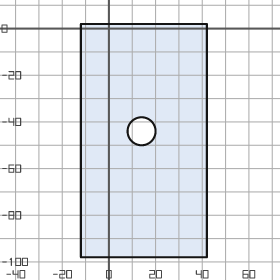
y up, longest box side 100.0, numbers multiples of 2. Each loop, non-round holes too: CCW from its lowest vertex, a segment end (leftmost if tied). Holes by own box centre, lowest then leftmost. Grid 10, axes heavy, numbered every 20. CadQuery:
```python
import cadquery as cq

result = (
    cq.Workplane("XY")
    .moveTo(-12.0, -98.0)
    .lineTo(42.0, -98.0)
    .lineTo(42.0, 2.0)
    .lineTo(-12.0, 2.0)
    .close()
    .moveTo(14.0, -44.0)
    .circle(6.0)
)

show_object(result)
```